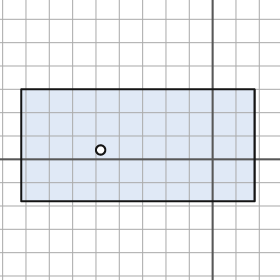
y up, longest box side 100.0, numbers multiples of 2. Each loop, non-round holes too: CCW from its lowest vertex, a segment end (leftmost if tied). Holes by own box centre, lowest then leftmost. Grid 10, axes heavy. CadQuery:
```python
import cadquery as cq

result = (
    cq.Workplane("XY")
    .moveTo(-82.0, -18.0)
    .lineTo(18.0, -18.0)
    .lineTo(18.0, 30.0)
    .lineTo(-82.0, 30.0)
    .close()
    .moveTo(-48.0, 4.0)
    .circle(2.0)
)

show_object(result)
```